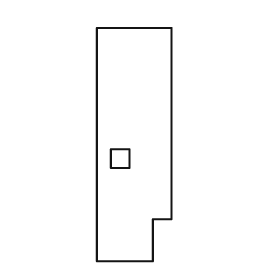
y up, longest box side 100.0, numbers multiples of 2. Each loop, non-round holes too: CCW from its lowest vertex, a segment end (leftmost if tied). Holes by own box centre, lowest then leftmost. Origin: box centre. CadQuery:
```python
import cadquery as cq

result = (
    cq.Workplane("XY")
    .moveTo(-16.0, -50.0)
    .lineTo(8.0, -50.0)
    .lineTo(8.0, -32.0)
    .lineTo(16.0, -32.0)
    .lineTo(16.0, 50.0)
    .lineTo(-16.0, 50.0)
    .close()
    .moveTo(-10.0, -10.0)
    .lineTo(-2.0, -10.0)
    .lineTo(-2.0, -2.0)
    .lineTo(-10.0, -2.0)
    .close()
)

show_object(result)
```